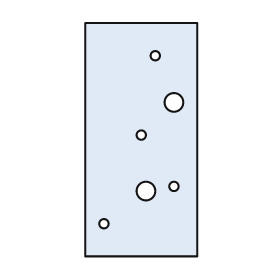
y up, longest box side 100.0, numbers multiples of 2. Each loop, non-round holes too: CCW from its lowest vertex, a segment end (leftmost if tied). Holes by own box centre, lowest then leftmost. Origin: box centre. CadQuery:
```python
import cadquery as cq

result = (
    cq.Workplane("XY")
    .moveTo(-24.0, -50.0)
    .lineTo(24.0, -50.0)
    .lineTo(24.0, 50.0)
    .lineTo(-24.0, 50.0)
    .close()
    .moveTo(-16.0, -36.0)
    .circle(2.0)
    .moveTo(2.0, -22.0)
    .circle(4.0)
    .moveTo(14.0, -20.0)
    .circle(2.0)
    .moveTo(0.0, 2.0)
    .circle(2.0)
    .moveTo(14.0, 16.0)
    .circle(4.0)
    .moveTo(6.0, 36.0)
    .circle(2.0)
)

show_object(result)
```